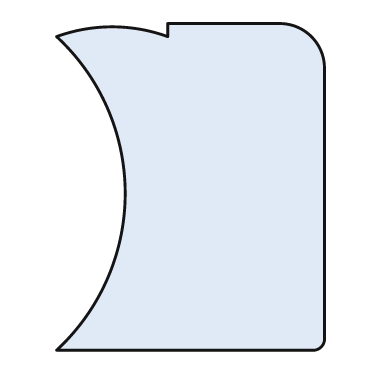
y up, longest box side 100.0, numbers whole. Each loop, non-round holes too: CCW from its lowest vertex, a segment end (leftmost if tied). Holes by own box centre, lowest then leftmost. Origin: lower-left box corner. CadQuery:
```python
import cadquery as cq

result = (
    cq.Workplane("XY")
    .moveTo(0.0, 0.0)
    .lineTo(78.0, 0.0)
    .threePointArc((81.0, 1.0), (82.0, 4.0))
    .lineTo(82.0, 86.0)
    .threePointArc((78.0, 96.0), (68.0, 100.0))
    .lineTo(34.0, 100.0)
    .lineTo(34.0, 96.0)
    .threePointArc((17.0, 99.0), (0.0, 96.0))
    .threePointArc((21.0, 48.0), (0.0, 0.0))
    .close()
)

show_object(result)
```